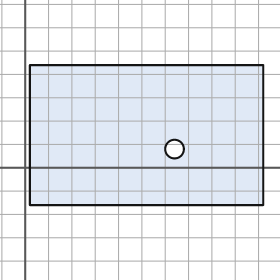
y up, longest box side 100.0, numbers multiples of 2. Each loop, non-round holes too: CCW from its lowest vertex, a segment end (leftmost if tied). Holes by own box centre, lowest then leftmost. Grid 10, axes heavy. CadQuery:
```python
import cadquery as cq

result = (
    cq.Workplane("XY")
    .moveTo(2.0, -16.0)
    .lineTo(102.0, -16.0)
    .lineTo(102.0, 44.0)
    .lineTo(2.0, 44.0)
    .close()
    .moveTo(64.0, 8.0)
    .circle(4.0)
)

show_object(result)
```